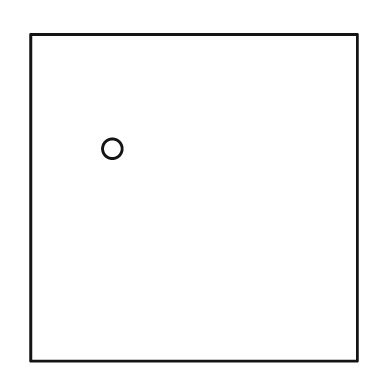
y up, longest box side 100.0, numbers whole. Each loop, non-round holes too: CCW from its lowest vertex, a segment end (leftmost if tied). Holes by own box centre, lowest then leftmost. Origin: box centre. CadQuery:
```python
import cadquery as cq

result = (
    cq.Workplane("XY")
    .moveTo(-50.0, -50.0)
    .lineTo(50.0, -50.0)
    .lineTo(50.0, 50.0)
    .lineTo(-50.0, 50.0)
    .close()
    .moveTo(-25.0, 15.0)
    .circle(3.0)
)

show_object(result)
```